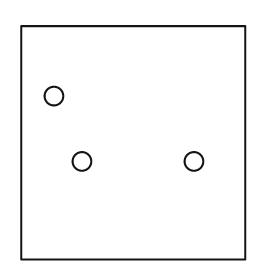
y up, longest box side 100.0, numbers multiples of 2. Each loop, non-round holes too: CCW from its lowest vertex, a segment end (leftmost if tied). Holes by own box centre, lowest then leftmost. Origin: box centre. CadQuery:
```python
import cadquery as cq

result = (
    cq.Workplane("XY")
    .moveTo(-48.0, -50.0)
    .lineTo(48.0, -50.0)
    .lineTo(48.0, 50.0)
    .lineTo(-48.0, 50.0)
    .close()
    .moveTo(-22.0, -8.0)
    .circle(4.0)
    .moveTo(26.0, -8.0)
    .circle(4.0)
    .moveTo(-34.0, 20.0)
    .circle(4.0)
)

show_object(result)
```